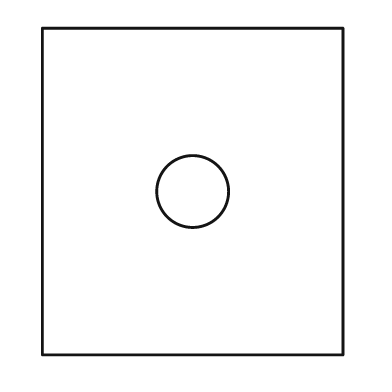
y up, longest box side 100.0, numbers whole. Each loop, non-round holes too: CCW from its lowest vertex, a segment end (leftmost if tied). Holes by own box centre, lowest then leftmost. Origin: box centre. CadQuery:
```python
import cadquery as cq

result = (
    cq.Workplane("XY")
    .moveTo(-46.0, -50.0)
    .lineTo(46.0, -50.0)
    .lineTo(46.0, 50.0)
    .lineTo(-46.0, 50.0)
    .close()
    .moveTo(0.0, 0.0)
    .circle(11.0)
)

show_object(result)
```